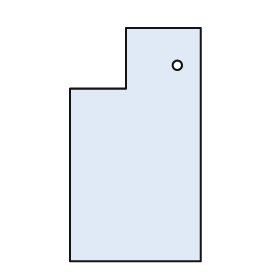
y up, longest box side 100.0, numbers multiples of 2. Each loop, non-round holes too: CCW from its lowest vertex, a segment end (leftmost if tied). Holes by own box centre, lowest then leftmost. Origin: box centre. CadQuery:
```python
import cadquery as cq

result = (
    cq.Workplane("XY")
    .moveTo(-28.0, -50.0)
    .lineTo(28.0, -50.0)
    .lineTo(28.0, 50.0)
    .lineTo(-4.0, 50.0)
    .lineTo(-4.0, 24.0)
    .lineTo(-28.0, 24.0)
    .close()
    .moveTo(18.0, 34.0)
    .circle(2.0)
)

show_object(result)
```